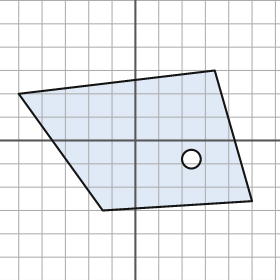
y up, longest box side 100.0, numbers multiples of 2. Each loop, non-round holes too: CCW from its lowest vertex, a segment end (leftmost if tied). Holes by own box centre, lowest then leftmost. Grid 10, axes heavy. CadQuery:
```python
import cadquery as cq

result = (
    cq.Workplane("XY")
    .moveTo(-14.0, -30.0)
    .lineTo(50.0, -26.0)
    .lineTo(34.0, 30.0)
    .lineTo(-50.0, 20.0)
    .close()
    .moveTo(24.0, -8.0)
    .circle(4.0)
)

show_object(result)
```